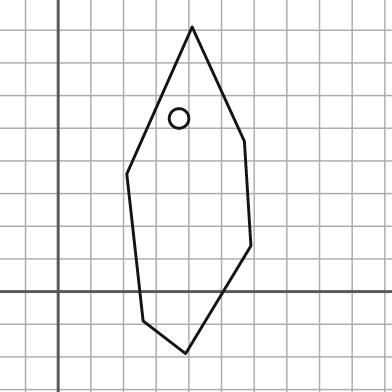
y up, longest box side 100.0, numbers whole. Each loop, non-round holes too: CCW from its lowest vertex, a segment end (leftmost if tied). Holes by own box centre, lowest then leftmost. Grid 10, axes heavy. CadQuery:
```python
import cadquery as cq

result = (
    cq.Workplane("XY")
    .moveTo(39.0, -19.0)
    .lineTo(59.0, 14.0)
    .lineTo(57.0, 46.0)
    .lineTo(41.0, 81.0)
    .lineTo(21.0, 36.0)
    .lineTo(26.0, -9.0)
    .close()
    .moveTo(37.0, 53.0)
    .circle(3.0)
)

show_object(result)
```